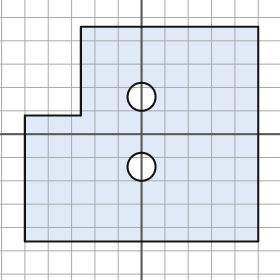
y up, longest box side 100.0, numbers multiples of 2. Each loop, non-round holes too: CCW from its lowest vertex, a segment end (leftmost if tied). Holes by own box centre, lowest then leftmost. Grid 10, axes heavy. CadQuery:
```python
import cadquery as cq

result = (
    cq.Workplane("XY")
    .moveTo(-50.0, -46.0)
    .lineTo(50.0, -46.0)
    .lineTo(50.0, 46.0)
    .lineTo(-26.0, 46.0)
    .lineTo(-26.0, 8.0)
    .lineTo(-50.0, 8.0)
    .close()
    .moveTo(0.0, -14.0)
    .circle(6.0)
    .moveTo(0.0, 16.0)
    .circle(6.0)
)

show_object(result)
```